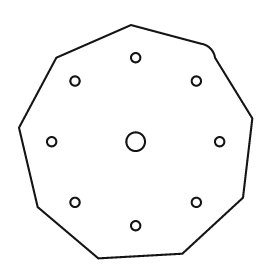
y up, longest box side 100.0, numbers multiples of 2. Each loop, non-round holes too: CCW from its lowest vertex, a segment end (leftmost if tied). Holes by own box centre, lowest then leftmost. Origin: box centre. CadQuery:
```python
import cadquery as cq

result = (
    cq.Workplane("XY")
    .moveTo(-16.0, -50.0)
    .lineTo(20.0, -48.0)
    .lineTo(46.0, -24.0)
    .lineTo(50.0, 10.0)
    .lineTo(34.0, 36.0)
    .threePointArc((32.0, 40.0), (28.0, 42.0))
    .lineTo(-2.0, 50.0)
    .lineTo(-34.0, 36.0)
    .lineTo(-50.0, 6.0)
    .lineTo(-42.0, -28.0)
    .close()
    .moveTo(0.0, -36.0)
    .circle(2.0)
    .moveTo(-26.0, -26.0)
    .circle(2.0)
    .moveTo(26.0, -26.0)
    .circle(2.0)
    .moveTo(-36.0, 0.0)
    .circle(2.0)
    .moveTo(0.0, 0.0)
    .circle(4.0)
    .moveTo(36.0, 0.0)
    .circle(2.0)
    .moveTo(-26.0, 26.0)
    .circle(2.0)
    .moveTo(26.0, 26.0)
    .circle(2.0)
    .moveTo(0.0, 36.0)
    .circle(2.0)
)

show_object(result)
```